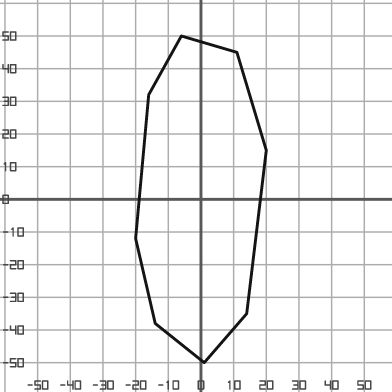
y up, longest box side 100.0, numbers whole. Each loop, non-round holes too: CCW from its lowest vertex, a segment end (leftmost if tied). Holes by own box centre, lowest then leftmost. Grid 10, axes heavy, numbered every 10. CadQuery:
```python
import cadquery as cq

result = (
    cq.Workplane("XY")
    .moveTo(1.0, -50.0)
    .lineTo(14.0, -35.0)
    .lineTo(20.0, 15.0)
    .lineTo(11.0, 45.0)
    .lineTo(-6.0, 50.0)
    .lineTo(-16.0, 32.0)
    .lineTo(-20.0, -12.0)
    .lineTo(-14.0, -38.0)
    .close()
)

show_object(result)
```